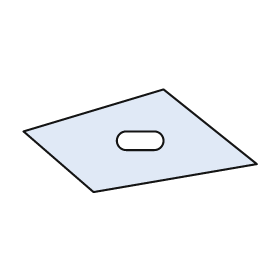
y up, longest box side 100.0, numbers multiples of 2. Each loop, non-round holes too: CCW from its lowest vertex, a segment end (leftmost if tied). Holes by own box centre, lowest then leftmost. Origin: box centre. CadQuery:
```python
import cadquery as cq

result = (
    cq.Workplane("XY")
    .moveTo(-20.0, -22.0)
    .lineTo(50.0, -10.0)
    .lineTo(10.0, 22.0)
    .lineTo(-50.0, 4.0)
    .close()
    .moveTo(-6.0, -4.0)
    .lineTo(6.0, -4.0)
    .threePointArc((10.0, 0.0), (6.0, 4.0))
    .lineTo(-6.0, 4.0)
    .threePointArc((-10.0, 0.0), (-6.0, -4.0))
    .close()
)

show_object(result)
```